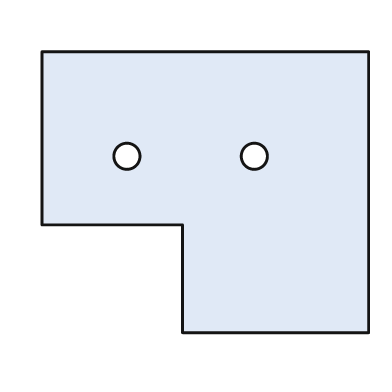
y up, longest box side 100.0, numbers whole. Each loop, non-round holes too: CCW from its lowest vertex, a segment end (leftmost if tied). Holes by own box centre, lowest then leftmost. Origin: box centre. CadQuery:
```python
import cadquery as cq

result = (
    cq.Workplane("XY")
    .moveTo(-7.0, -43.0)
    .lineTo(50.0, -43.0)
    .lineTo(50.0, 43.0)
    .lineTo(-50.0, 43.0)
    .lineTo(-50.0, -10.0)
    .lineTo(-7.0, -10.0)
    .close()
    .moveTo(-24.0, 11.0)
    .circle(4.0)
    .moveTo(15.0, 11.0)
    .circle(4.0)
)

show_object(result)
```